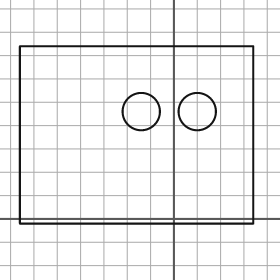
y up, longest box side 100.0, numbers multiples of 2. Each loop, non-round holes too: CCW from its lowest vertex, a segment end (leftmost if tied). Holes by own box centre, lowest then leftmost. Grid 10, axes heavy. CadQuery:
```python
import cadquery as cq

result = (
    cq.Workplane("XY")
    .moveTo(-66.0, -2.0)
    .lineTo(34.0, -2.0)
    .lineTo(34.0, 74.0)
    .lineTo(-66.0, 74.0)
    .close()
    .moveTo(-14.0, 46.0)
    .circle(8.0)
    .moveTo(10.0, 46.0)
    .circle(8.0)
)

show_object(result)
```